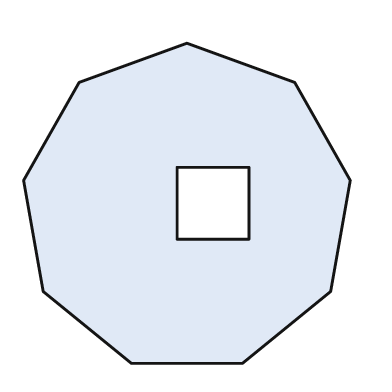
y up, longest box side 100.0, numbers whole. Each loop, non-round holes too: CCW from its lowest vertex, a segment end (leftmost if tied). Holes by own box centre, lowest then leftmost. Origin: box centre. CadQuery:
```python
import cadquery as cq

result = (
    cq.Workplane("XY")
    .moveTo(-17.0, -49.0)
    .lineTo(17.0, -49.0)
    .lineTo(44.0, -27.0)
    .lineTo(50.0, 7.0)
    .lineTo(33.0, 37.0)
    .lineTo(0.0, 49.0)
    .lineTo(-33.0, 37.0)
    .lineTo(-50.0, 7.0)
    .lineTo(-44.0, -27.0)
    .close()
    .moveTo(-3.0, -11.0)
    .lineTo(19.0, -11.0)
    .lineTo(19.0, 11.0)
    .lineTo(-3.0, 11.0)
    .close()
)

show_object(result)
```